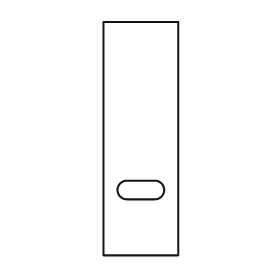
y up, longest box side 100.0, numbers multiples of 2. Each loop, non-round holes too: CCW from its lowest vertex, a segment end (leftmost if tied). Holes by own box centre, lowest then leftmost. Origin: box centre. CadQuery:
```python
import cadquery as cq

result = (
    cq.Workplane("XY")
    .moveTo(-16.0, -50.0)
    .lineTo(16.0, -50.0)
    .lineTo(16.0, 50.0)
    .lineTo(-16.0, 50.0)
    .close()
    .moveTo(-6.0, -26.0)
    .lineTo(6.0, -26.0)
    .threePointArc((10.0, -22.0), (6.0, -18.0))
    .lineTo(-6.0, -18.0)
    .threePointArc((-10.0, -22.0), (-6.0, -26.0))
    .close()
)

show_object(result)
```